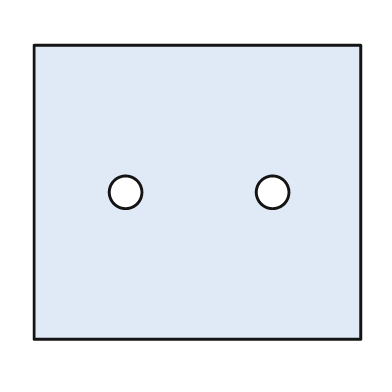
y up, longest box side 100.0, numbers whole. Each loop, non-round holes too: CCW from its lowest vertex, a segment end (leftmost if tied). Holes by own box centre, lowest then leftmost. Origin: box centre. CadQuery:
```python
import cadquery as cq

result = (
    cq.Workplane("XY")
    .moveTo(-50.0, -45.0)
    .lineTo(50.0, -45.0)
    .lineTo(50.0, 45.0)
    .lineTo(-50.0, 45.0)
    .close()
    .moveTo(-22.0, 0.0)
    .circle(5.0)
    .moveTo(23.0, 0.0)
    .circle(5.0)
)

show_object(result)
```